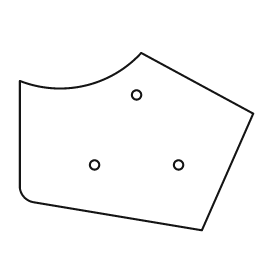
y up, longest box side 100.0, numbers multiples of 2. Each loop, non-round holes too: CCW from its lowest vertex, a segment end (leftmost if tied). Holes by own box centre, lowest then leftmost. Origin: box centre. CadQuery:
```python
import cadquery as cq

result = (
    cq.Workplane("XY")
    .moveTo(28.0, -38.0)
    .lineTo(50.0, 12.0)
    .lineTo(2.0, 38.0)
    .threePointArc((-22.0, 24.0), (-50.0, 26.0))
    .lineTo(-50.0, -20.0)
    .threePointArc((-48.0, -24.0), (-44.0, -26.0))
    .close()
    .moveTo(-18.0, -10.0)
    .circle(2.0)
    .moveTo(18.0, -10.0)
    .circle(2.0)
    .moveTo(0.0, 20.0)
    .circle(2.0)
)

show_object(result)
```